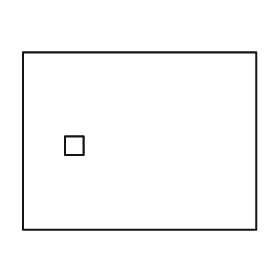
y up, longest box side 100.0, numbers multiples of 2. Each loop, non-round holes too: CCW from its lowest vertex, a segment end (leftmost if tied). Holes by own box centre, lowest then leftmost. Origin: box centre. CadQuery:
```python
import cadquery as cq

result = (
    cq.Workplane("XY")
    .moveTo(-50.0, -38.0)
    .lineTo(50.0, -38.0)
    .lineTo(50.0, 38.0)
    .lineTo(-50.0, 38.0)
    .close()
    .moveTo(-32.0, -6.0)
    .lineTo(-24.0, -6.0)
    .lineTo(-24.0, 2.0)
    .lineTo(-32.0, 2.0)
    .close()
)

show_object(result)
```